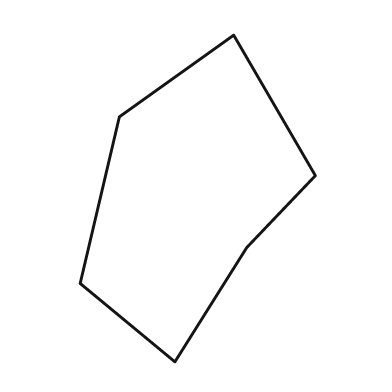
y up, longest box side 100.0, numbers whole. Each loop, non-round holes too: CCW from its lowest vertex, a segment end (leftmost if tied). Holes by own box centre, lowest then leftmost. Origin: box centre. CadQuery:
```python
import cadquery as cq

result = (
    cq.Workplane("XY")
    .moveTo(-7.0, -50.0)
    .lineTo(15.0, -15.0)
    .lineTo(36.0, 7.0)
    .lineTo(11.0, 50.0)
    .lineTo(-24.0, 25.0)
    .lineTo(-36.0, -26.0)
    .close()
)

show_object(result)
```